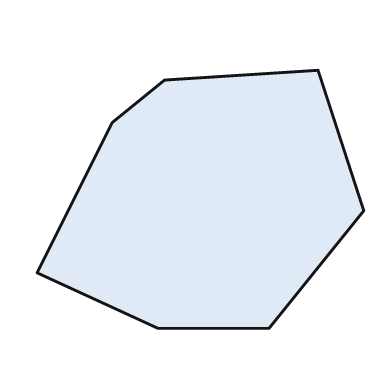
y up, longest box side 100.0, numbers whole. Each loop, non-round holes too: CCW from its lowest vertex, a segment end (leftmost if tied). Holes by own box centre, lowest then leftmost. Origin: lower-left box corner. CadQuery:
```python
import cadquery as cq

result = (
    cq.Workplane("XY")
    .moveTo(37.0, 0.0)
    .lineTo(71.0, 0.0)
    .lineTo(100.0, 36.0)
    .lineTo(86.0, 79.0)
    .lineTo(39.0, 76.0)
    .lineTo(23.0, 63.0)
    .lineTo(0.0, 17.0)
    .close()
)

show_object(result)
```